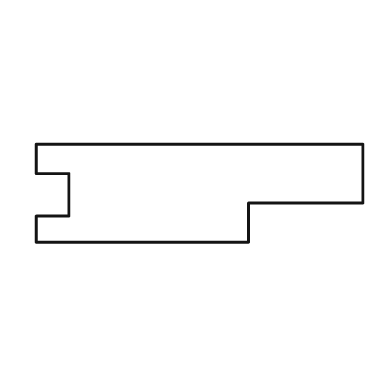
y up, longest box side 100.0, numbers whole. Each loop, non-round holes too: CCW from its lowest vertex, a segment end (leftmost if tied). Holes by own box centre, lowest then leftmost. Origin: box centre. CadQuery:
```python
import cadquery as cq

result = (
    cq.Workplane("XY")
    .moveTo(-50.0, -15.0)
    .lineTo(15.0, -15.0)
    .lineTo(15.0, -3.0)
    .lineTo(50.0, -3.0)
    .lineTo(50.0, 15.0)
    .lineTo(-50.0, 15.0)
    .lineTo(-50.0, 6.0)
    .lineTo(-40.0, 6.0)
    .lineTo(-40.0, -7.0)
    .lineTo(-50.0, -7.0)
    .close()
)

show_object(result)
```